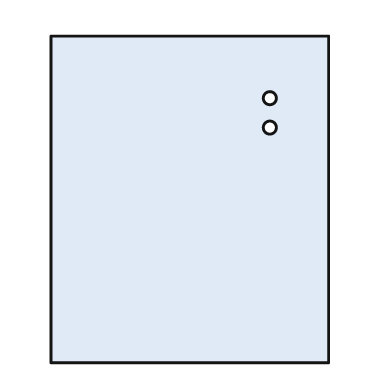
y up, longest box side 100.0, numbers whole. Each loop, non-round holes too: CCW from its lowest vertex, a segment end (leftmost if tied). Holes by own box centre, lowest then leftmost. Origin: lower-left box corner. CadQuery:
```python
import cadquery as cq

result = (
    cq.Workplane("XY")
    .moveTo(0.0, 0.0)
    .lineTo(85.0, 0.0)
    .lineTo(85.0, 100.0)
    .lineTo(0.0, 100.0)
    .close()
    .moveTo(67.0, 72.0)
    .circle(2.0)
    .moveTo(67.0, 81.0)
    .circle(2.0)
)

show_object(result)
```